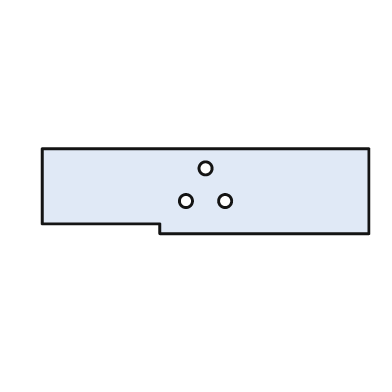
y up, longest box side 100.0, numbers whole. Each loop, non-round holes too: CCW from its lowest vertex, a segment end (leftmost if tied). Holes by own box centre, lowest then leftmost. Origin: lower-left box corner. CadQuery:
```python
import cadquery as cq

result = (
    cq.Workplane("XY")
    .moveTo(36.0, 0.0)
    .lineTo(100.0, 0.0)
    .lineTo(100.0, 26.0)
    .lineTo(0.0, 26.0)
    .lineTo(0.0, 3.0)
    .lineTo(36.0, 3.0)
    .close()
    .moveTo(44.0, 10.0)
    .circle(2.0)
    .moveTo(56.0, 10.0)
    .circle(2.0)
    .moveTo(50.0, 20.0)
    .circle(2.0)
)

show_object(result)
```